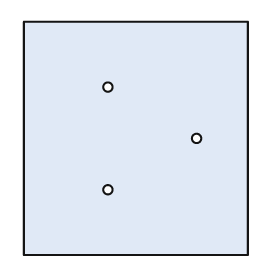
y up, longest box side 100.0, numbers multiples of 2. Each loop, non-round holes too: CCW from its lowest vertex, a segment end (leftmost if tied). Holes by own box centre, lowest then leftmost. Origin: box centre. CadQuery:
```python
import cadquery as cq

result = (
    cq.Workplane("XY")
    .moveTo(-48.0, -50.0)
    .lineTo(48.0, -50.0)
    .lineTo(48.0, 50.0)
    .lineTo(-48.0, 50.0)
    .close()
    .moveTo(-12.0, -22.0)
    .circle(2.0)
    .moveTo(26.0, 0.0)
    .circle(2.0)
    .moveTo(-12.0, 22.0)
    .circle(2.0)
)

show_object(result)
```